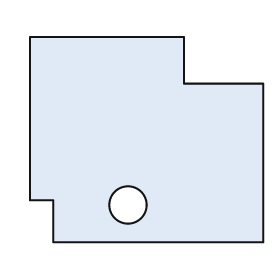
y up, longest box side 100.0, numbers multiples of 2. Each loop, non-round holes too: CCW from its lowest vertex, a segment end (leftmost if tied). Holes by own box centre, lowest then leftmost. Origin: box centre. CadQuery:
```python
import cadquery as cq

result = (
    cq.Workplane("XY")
    .moveTo(-40.0, -44.0)
    .lineTo(50.0, -44.0)
    .lineTo(50.0, 24.0)
    .lineTo(16.0, 24.0)
    .lineTo(16.0, 44.0)
    .lineTo(-50.0, 44.0)
    .lineTo(-50.0, -26.0)
    .lineTo(-40.0, -26.0)
    .close()
    .moveTo(-8.0, -28.0)
    .circle(8.0)
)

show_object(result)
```